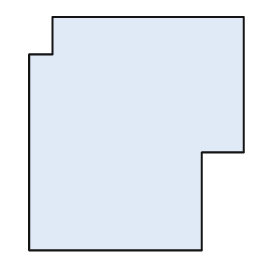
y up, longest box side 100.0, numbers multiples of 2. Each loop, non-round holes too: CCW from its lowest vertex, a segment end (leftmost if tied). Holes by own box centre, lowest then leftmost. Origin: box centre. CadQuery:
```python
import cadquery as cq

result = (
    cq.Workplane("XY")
    .moveTo(-46.0, -50.0)
    .lineTo(28.0, -50.0)
    .lineTo(28.0, -8.0)
    .lineTo(46.0, -8.0)
    .lineTo(46.0, 50.0)
    .lineTo(-36.0, 50.0)
    .lineTo(-36.0, 34.0)
    .lineTo(-46.0, 34.0)
    .close()
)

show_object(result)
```